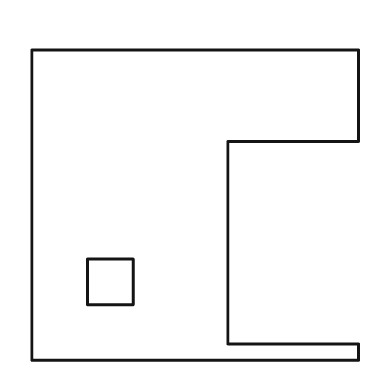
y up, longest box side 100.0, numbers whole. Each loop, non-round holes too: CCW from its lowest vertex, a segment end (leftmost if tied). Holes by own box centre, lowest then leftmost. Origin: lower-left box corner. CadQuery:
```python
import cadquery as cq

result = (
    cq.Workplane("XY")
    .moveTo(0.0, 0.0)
    .lineTo(100.0, 0.0)
    .lineTo(100.0, 5.0)
    .lineTo(60.0, 5.0)
    .lineTo(60.0, 67.0)
    .lineTo(100.0, 67.0)
    .lineTo(100.0, 95.0)
    .lineTo(0.0, 95.0)
    .close()
    .moveTo(17.0, 17.0)
    .lineTo(31.0, 17.0)
    .lineTo(31.0, 31.0)
    .lineTo(17.0, 31.0)
    .close()
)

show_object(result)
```